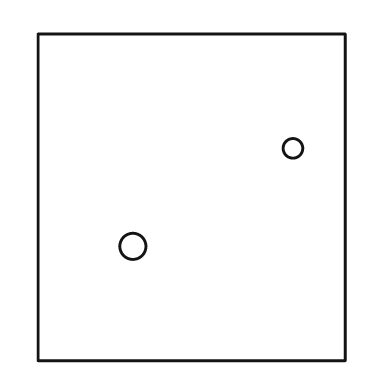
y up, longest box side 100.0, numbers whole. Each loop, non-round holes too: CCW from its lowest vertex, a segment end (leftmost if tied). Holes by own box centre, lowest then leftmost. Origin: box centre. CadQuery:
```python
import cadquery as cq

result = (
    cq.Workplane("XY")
    .moveTo(-47.0, -50.0)
    .lineTo(47.0, -50.0)
    .lineTo(47.0, 50.0)
    .lineTo(-47.0, 50.0)
    .close()
    .moveTo(-18.0, -15.0)
    .circle(4.0)
    .moveTo(31.0, 15.0)
    .circle(3.0)
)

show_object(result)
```